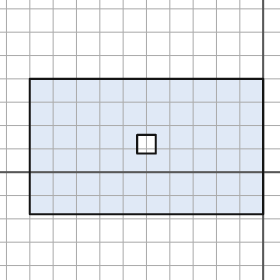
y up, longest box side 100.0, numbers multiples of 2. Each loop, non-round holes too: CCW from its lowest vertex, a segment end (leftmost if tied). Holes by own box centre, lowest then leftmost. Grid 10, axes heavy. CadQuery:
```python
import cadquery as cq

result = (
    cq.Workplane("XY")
    .moveTo(-100.0, -18.0)
    .lineTo(0.0, -18.0)
    .lineTo(0.0, 40.0)
    .lineTo(-100.0, 40.0)
    .close()
    .moveTo(-54.0, 8.0)
    .lineTo(-46.0, 8.0)
    .lineTo(-46.0, 16.0)
    .lineTo(-54.0, 16.0)
    .close()
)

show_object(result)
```